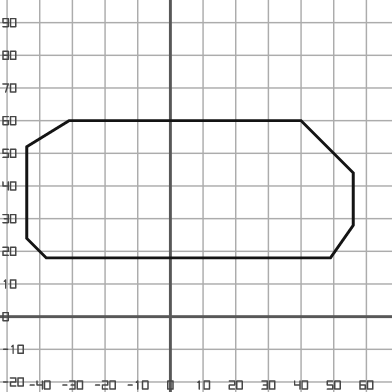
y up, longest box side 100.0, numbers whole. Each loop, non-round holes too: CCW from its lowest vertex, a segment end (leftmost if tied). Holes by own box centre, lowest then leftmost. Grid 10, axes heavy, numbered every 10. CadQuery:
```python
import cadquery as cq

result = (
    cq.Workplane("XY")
    .moveTo(-38.0, 18.0)
    .lineTo(49.0, 18.0)
    .lineTo(56.0, 28.0)
    .lineTo(56.0, 44.0)
    .lineTo(40.0, 60.0)
    .lineTo(-31.0, 60.0)
    .lineTo(-44.0, 52.0)
    .lineTo(-44.0, 24.0)
    .close()
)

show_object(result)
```